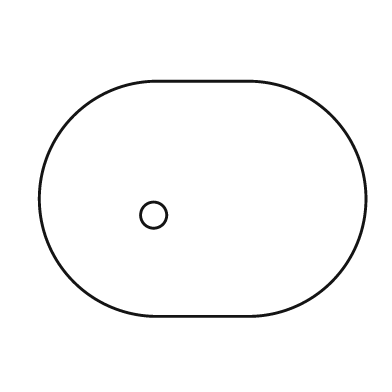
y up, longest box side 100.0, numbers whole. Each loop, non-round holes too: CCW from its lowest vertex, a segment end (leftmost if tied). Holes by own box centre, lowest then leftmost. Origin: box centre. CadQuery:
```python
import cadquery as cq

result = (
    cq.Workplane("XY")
    .moveTo(-14.0, -36.0)
    .lineTo(14.0, -36.0)
    .threePointArc((50.0, 0.0), (14.0, 36.0))
    .lineTo(-14.0, 36.0)
    .threePointArc((-50.0, 0.0), (-14.0, -36.0))
    .close()
    .moveTo(-15.0, -5.0)
    .circle(4.0)
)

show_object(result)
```